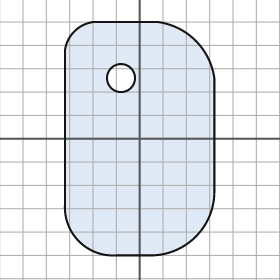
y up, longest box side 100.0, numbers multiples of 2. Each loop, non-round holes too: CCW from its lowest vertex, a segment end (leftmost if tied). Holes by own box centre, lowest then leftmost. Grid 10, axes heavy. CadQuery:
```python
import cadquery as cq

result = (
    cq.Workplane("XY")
    .moveTo(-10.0, -50.0)
    .lineTo(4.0, -50.0)
    .threePointArc((24.0, -42.0), (32.0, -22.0))
    .lineTo(32.0, 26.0)
    .threePointArc((24.0, 42.0), (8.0, 50.0))
    .lineTo(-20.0, 50.0)
    .threePointArc((-28.0, 46.0), (-32.0, 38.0))
    .lineTo(-32.0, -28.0)
    .threePointArc((-26.0, -44.0), (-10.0, -50.0))
    .close()
    .moveTo(-8.0, 26.0)
    .circle(6.0)
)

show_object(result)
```